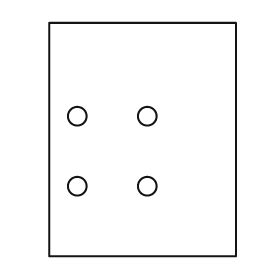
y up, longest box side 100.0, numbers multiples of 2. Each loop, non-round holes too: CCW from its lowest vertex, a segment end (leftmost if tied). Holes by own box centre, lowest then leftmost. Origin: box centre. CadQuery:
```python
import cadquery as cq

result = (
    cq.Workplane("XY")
    .moveTo(-40.0, -50.0)
    .lineTo(40.0, -50.0)
    .lineTo(40.0, 50.0)
    .lineTo(-40.0, 50.0)
    .close()
    .moveTo(-28.0, -20.0)
    .circle(4.0)
    .moveTo(2.0, -20.0)
    .circle(4.0)
    .moveTo(-28.0, 10.0)
    .circle(4.0)
    .moveTo(2.0, 10.0)
    .circle(4.0)
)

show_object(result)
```